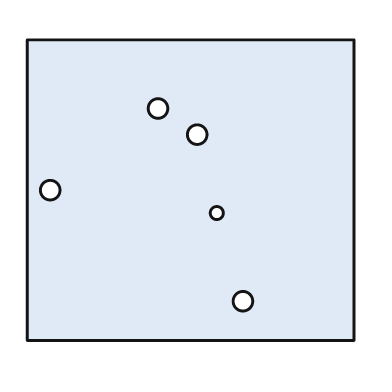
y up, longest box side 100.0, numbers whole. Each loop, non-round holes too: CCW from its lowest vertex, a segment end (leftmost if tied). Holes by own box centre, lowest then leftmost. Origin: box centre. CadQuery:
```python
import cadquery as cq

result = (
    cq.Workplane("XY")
    .moveTo(-50.0, -46.0)
    .lineTo(50.0, -46.0)
    .lineTo(50.0, 46.0)
    .lineTo(-50.0, 46.0)
    .close()
    .moveTo(16.0, -34.0)
    .circle(3.0)
    .moveTo(8.0, -7.0)
    .circle(2.0)
    .moveTo(-43.0, 0.0)
    .circle(3.0)
    .moveTo(2.0, 17.0)
    .circle(3.0)
    .moveTo(-10.0, 25.0)
    .circle(3.0)
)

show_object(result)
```